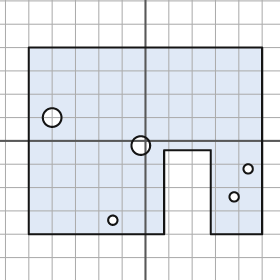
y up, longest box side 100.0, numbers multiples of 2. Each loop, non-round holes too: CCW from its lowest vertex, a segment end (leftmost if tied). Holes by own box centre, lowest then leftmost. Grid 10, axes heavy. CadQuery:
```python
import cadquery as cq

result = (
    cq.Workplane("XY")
    .moveTo(-50.0, -40.0)
    .lineTo(8.0, -40.0)
    .lineTo(8.0, -4.0)
    .lineTo(28.0, -4.0)
    .lineTo(28.0, -40.0)
    .lineTo(50.0, -40.0)
    .lineTo(50.0, 40.0)
    .lineTo(-50.0, 40.0)
    .close()
    .moveTo(-14.0, -34.0)
    .circle(2.0)
    .moveTo(38.0, -24.0)
    .circle(2.0)
    .moveTo(44.0, -12.0)
    .circle(2.0)
    .moveTo(-2.0, -2.0)
    .circle(4.0)
    .moveTo(-40.0, 10.0)
    .circle(4.0)
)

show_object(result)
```